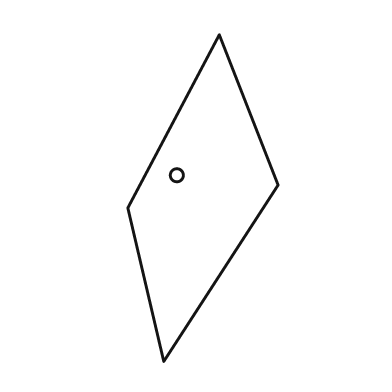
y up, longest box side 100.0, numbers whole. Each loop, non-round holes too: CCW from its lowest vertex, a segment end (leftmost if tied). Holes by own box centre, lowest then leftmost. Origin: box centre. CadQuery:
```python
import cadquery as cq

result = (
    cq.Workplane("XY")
    .moveTo(-12.0, -50.0)
    .lineTo(23.0, 4.0)
    .lineTo(5.0, 50.0)
    .lineTo(-23.0, -3.0)
    .close()
    .moveTo(-8.0, 7.0)
    .circle(2.0)
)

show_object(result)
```